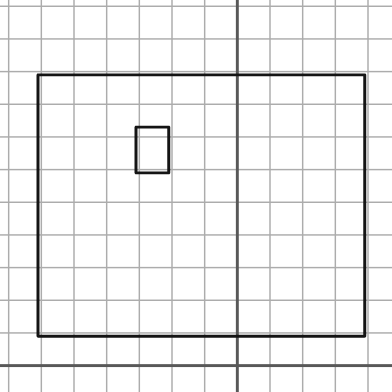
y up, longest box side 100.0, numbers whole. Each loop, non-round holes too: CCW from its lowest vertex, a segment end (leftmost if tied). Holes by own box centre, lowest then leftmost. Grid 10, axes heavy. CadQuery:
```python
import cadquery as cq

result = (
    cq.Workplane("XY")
    .moveTo(-61.0, 9.0)
    .lineTo(39.0, 9.0)
    .lineTo(39.0, 89.0)
    .lineTo(-61.0, 89.0)
    .close()
    .moveTo(-31.0, 59.0)
    .lineTo(-21.0, 59.0)
    .lineTo(-21.0, 73.0)
    .lineTo(-31.0, 73.0)
    .close()
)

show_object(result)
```